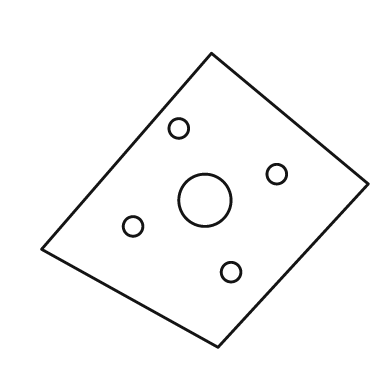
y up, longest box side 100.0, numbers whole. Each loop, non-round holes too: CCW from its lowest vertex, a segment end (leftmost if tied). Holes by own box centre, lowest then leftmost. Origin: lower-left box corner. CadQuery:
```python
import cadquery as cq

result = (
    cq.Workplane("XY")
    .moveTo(54.0, 0.0)
    .lineTo(100.0, 50.0)
    .lineTo(52.0, 90.0)
    .lineTo(0.0, 30.0)
    .close()
    .moveTo(58.0, 23.0)
    .circle(3.0)
    .moveTo(28.0, 37.0)
    .circle(3.0)
    .moveTo(50.0, 45.0)
    .circle(8.0)
    .moveTo(72.0, 53.0)
    .circle(3.0)
    .moveTo(42.0, 67.0)
    .circle(3.0)
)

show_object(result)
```